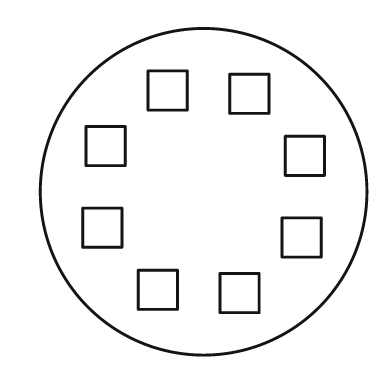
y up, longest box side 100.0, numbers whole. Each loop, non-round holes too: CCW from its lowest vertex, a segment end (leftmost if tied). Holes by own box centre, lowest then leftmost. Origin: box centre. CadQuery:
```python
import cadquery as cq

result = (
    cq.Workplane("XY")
    .moveTo(0.0, 0.0)
    .circle(50.0)
    .moveTo(5.0, -37.0)
    .lineTo(17.0, -37.0)
    .lineTo(17.0, -25.0)
    .lineTo(5.0, -25.0)
    .close()
    .moveTo(-20.0, -36.0)
    .lineTo(-8.0, -36.0)
    .lineTo(-8.0, -24.0)
    .lineTo(-20.0, -24.0)
    .close()
    .moveTo(24.0, -20.0)
    .lineTo(36.0, -20.0)
    .lineTo(36.0, -8.0)
    .lineTo(24.0, -8.0)
    .close()
    .moveTo(-37.0, -17.0)
    .lineTo(-25.0, -17.0)
    .lineTo(-25.0, -5.0)
    .lineTo(-37.0, -5.0)
    .close()
    .moveTo(25.0, 5.0)
    .lineTo(37.0, 5.0)
    .lineTo(37.0, 17.0)
    .lineTo(25.0, 17.0)
    .close()
    .moveTo(-36.0, 8.0)
    .lineTo(-24.0, 8.0)
    .lineTo(-24.0, 20.0)
    .lineTo(-36.0, 20.0)
    .close()
    .moveTo(8.0, 24.0)
    .lineTo(20.0, 24.0)
    .lineTo(20.0, 36.0)
    .lineTo(8.0, 36.0)
    .close()
    .moveTo(-17.0, 25.0)
    .lineTo(-5.0, 25.0)
    .lineTo(-5.0, 37.0)
    .lineTo(-17.0, 37.0)
    .close()
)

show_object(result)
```